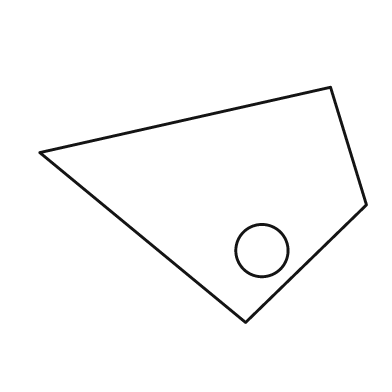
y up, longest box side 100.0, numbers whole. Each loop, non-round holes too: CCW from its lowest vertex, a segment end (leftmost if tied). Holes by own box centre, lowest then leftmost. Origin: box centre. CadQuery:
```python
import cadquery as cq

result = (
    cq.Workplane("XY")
    .moveTo(13.0, -36.0)
    .lineTo(50.0, 0.0)
    .lineTo(39.0, 36.0)
    .lineTo(-50.0, 16.0)
    .close()
    .moveTo(18.0, -14.0)
    .circle(8.0)
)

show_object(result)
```